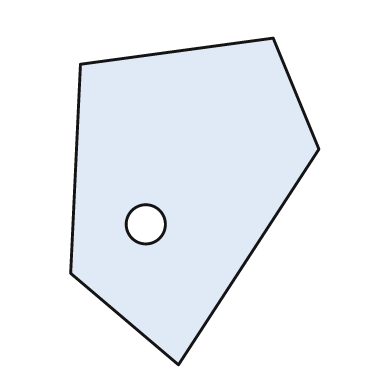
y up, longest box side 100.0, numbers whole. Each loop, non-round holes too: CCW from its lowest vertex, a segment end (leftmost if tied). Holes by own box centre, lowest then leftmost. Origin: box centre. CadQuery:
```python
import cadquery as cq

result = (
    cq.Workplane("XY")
    .moveTo(-5.0, -50.0)
    .lineTo(38.0, 16.0)
    .lineTo(24.0, 50.0)
    .lineTo(-35.0, 42.0)
    .lineTo(-38.0, -22.0)
    .close()
    .moveTo(-15.0, -7.0)
    .circle(6.0)
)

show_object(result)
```